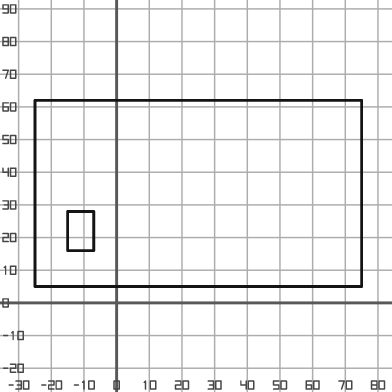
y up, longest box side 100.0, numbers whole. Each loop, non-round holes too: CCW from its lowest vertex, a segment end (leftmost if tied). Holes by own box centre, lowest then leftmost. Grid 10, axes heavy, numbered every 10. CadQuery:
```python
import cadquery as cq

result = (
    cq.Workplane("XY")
    .moveTo(-25.0, 5.0)
    .lineTo(75.0, 5.0)
    .lineTo(75.0, 62.0)
    .lineTo(-25.0, 62.0)
    .close()
    .moveTo(-15.0, 16.0)
    .lineTo(-7.0, 16.0)
    .lineTo(-7.0, 28.0)
    .lineTo(-15.0, 28.0)
    .close()
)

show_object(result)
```